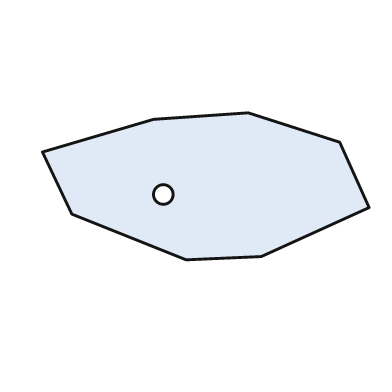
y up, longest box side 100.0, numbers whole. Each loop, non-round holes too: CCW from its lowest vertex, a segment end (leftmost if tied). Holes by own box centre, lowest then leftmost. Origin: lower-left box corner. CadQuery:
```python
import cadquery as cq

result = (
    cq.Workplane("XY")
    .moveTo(44.0, 0.0)
    .lineTo(67.0, 1.0)
    .lineTo(100.0, 16.0)
    .lineTo(91.0, 36.0)
    .lineTo(63.0, 45.0)
    .lineTo(34.0, 43.0)
    .lineTo(0.0, 33.0)
    .lineTo(9.0, 14.0)
    .close()
    .moveTo(37.0, 20.0)
    .circle(3.0)
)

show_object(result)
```